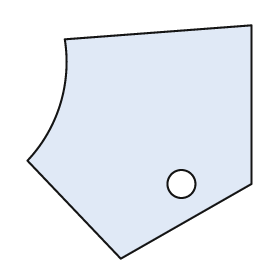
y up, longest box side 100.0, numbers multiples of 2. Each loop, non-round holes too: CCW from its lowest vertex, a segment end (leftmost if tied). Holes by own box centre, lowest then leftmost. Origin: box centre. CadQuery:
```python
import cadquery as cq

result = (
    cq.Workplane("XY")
    .moveTo(-8.0, -50.0)
    .lineTo(48.0, -18.0)
    .lineTo(48.0, 50.0)
    .lineTo(-32.0, 44.0)
    .threePointArc((-34.0, 16.0), (-48.0, -8.0))
    .close()
    .moveTo(18.0, -18.0)
    .circle(6.0)
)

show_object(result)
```